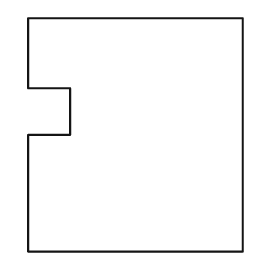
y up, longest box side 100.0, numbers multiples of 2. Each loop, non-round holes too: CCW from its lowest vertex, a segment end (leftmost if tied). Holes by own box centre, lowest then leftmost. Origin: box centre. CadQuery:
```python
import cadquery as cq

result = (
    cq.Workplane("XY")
    .moveTo(-46.0, -50.0)
    .lineTo(46.0, -50.0)
    .lineTo(46.0, 50.0)
    .lineTo(-46.0, 50.0)
    .lineTo(-46.0, 20.0)
    .lineTo(-28.0, 20.0)
    .lineTo(-28.0, 0.0)
    .lineTo(-46.0, 0.0)
    .close()
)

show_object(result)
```